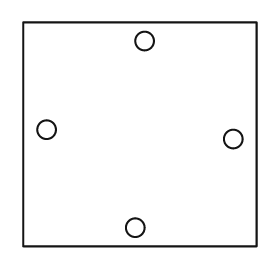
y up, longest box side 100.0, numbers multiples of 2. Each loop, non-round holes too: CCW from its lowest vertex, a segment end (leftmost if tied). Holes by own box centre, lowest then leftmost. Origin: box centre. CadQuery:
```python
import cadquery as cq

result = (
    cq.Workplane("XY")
    .moveTo(-50.0, -48.0)
    .lineTo(50.0, -48.0)
    .lineTo(50.0, 48.0)
    .lineTo(-50.0, 48.0)
    .close()
    .moveTo(-2.0, -40.0)
    .circle(4.0)
    .moveTo(40.0, -2.0)
    .circle(4.0)
    .moveTo(-40.0, 2.0)
    .circle(4.0)
    .moveTo(2.0, 40.0)
    .circle(4.0)
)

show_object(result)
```